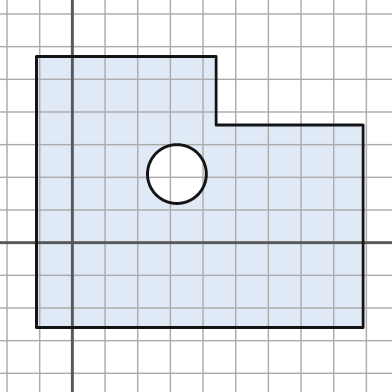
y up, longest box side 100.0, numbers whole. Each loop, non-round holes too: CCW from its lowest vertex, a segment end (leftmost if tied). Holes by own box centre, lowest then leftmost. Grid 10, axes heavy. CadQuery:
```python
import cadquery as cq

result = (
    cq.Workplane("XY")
    .moveTo(-11.0, -26.0)
    .lineTo(89.0, -26.0)
    .lineTo(89.0, 36.0)
    .lineTo(44.0, 36.0)
    .lineTo(44.0, 57.0)
    .lineTo(-11.0, 57.0)
    .close()
    .moveTo(32.0, 21.0)
    .circle(9.0)
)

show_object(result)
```